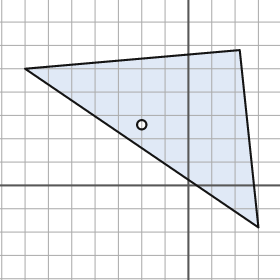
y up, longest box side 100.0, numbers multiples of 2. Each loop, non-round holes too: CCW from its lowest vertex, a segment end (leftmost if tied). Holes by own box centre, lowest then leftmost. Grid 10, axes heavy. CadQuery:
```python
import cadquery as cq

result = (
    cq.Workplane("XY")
    .moveTo(30.0, -18.0)
    .lineTo(22.0, 58.0)
    .lineTo(-70.0, 50.0)
    .close()
    .moveTo(-20.0, 26.0)
    .circle(2.0)
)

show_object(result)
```